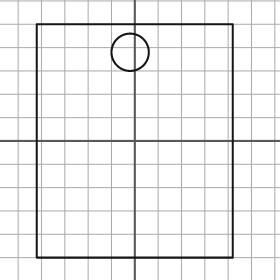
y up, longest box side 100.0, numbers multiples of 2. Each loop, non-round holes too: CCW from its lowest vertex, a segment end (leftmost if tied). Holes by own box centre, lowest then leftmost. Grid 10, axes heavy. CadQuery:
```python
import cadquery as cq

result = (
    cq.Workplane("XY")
    .moveTo(-42.0, -50.0)
    .lineTo(42.0, -50.0)
    .lineTo(42.0, 50.0)
    .lineTo(-42.0, 50.0)
    .close()
    .moveTo(-2.0, 38.0)
    .circle(8.0)
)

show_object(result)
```